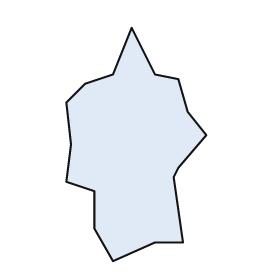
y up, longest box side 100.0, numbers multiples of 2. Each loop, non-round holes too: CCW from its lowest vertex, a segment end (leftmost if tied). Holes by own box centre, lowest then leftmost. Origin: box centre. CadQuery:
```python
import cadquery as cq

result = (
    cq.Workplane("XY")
    .moveTo(-10.0, -50.0)
    .lineTo(8.0, -42.0)
    .lineTo(20.0, -42.0)
    .lineTo(16.0, -14.0)
    .lineTo(18.0, -10.0)
    .lineTo(30.0, 4.0)
    .lineTo(22.0, 14.0)
    .lineTo(18.0, 28.0)
    .lineTo(8.0, 30.0)
    .lineTo(-2.0, 50.0)
    .lineTo(-10.0, 30.0)
    .lineTo(-22.0, 26.0)
    .lineTo(-30.0, 18.0)
    .lineTo(-28.0, 0.0)
    .lineTo(-30.0, -16.0)
    .lineTo(-18.0, -20.0)
    .lineTo(-18.0, -36.0)
    .close()
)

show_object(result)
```